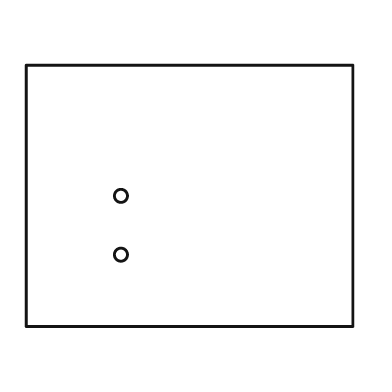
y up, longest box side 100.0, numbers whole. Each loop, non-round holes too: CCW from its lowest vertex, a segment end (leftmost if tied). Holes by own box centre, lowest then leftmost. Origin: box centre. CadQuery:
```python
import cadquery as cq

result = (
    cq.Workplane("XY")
    .moveTo(-50.0, -40.0)
    .lineTo(50.0, -40.0)
    .lineTo(50.0, 40.0)
    .lineTo(-50.0, 40.0)
    .close()
    .moveTo(-21.0, -18.0)
    .circle(2.0)
    .moveTo(-21.0, 0.0)
    .circle(2.0)
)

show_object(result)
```